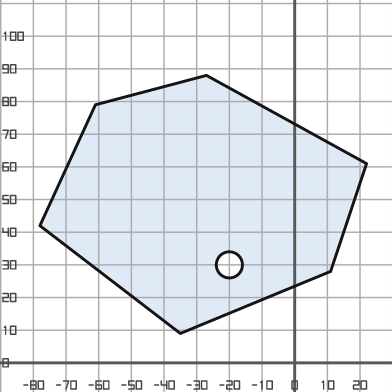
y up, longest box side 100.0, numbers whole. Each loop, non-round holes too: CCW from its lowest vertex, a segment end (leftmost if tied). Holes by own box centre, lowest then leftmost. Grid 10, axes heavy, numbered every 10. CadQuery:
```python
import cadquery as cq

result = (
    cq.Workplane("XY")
    .moveTo(-35.0, 9.0)
    .lineTo(11.0, 28.0)
    .lineTo(22.0, 61.0)
    .lineTo(-27.0, 88.0)
    .lineTo(-61.0, 79.0)
    .lineTo(-78.0, 42.0)
    .close()
    .moveTo(-20.0, 30.0)
    .circle(4.0)
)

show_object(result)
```